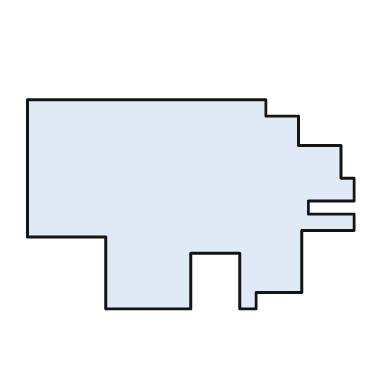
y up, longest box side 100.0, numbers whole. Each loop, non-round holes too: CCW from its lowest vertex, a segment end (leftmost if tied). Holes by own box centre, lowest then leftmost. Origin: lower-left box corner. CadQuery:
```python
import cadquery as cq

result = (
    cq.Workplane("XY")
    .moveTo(24.0, 0.0)
    .lineTo(50.0, 0.0)
    .lineTo(50.0, 17.0)
    .lineTo(65.0, 17.0)
    .lineTo(65.0, 0.0)
    .lineTo(70.0, 0.0)
    .lineTo(70.0, 5.0)
    .lineTo(84.0, 5.0)
    .lineTo(84.0, 24.0)
    .lineTo(100.0, 24.0)
    .lineTo(100.0, 29.0)
    .lineTo(86.0, 29.0)
    .lineTo(86.0, 33.0)
    .lineTo(100.0, 33.0)
    .lineTo(100.0, 40.0)
    .lineTo(96.0, 40.0)
    .lineTo(96.0, 50.0)
    .lineTo(83.0, 50.0)
    .lineTo(83.0, 59.0)
    .lineTo(73.0, 59.0)
    .lineTo(73.0, 64.0)
    .lineTo(0.0, 64.0)
    .lineTo(0.0, 22.0)
    .lineTo(24.0, 22.0)
    .close()
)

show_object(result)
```